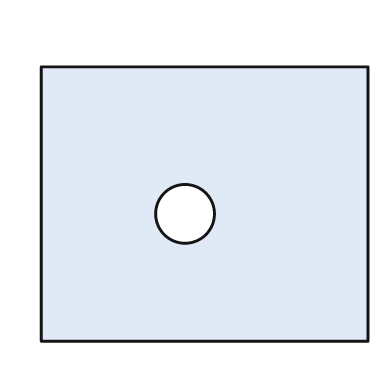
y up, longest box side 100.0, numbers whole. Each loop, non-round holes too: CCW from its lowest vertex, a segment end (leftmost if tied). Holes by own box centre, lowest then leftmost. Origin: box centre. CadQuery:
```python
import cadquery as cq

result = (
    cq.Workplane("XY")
    .moveTo(-50.0, -42.0)
    .lineTo(50.0, -42.0)
    .lineTo(50.0, 42.0)
    .lineTo(-50.0, 42.0)
    .close()
    .moveTo(-6.0, -3.0)
    .circle(9.0)
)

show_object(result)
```